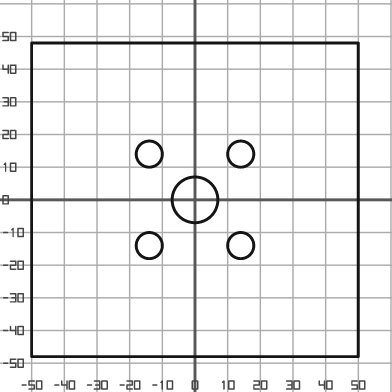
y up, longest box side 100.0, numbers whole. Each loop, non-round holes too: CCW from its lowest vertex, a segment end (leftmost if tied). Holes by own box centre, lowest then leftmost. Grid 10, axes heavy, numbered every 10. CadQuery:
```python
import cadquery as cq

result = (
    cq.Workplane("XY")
    .moveTo(-50.0, -48.0)
    .lineTo(50.0, -48.0)
    .lineTo(50.0, 48.0)
    .lineTo(-50.0, 48.0)
    .close()
    .moveTo(-14.0, -14.0)
    .circle(4.0)
    .moveTo(14.0, -14.0)
    .circle(4.0)
    .moveTo(0.0, 0.0)
    .circle(7.0)
    .moveTo(-14.0, 14.0)
    .circle(4.0)
    .moveTo(14.0, 14.0)
    .circle(4.0)
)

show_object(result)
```